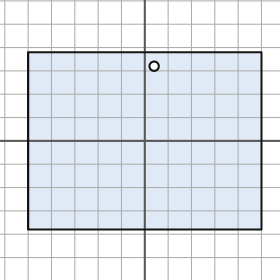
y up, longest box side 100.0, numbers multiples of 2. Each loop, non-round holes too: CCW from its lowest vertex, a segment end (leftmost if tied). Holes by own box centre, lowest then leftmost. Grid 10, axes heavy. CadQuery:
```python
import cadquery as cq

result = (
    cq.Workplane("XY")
    .moveTo(-50.0, -38.0)
    .lineTo(50.0, -38.0)
    .lineTo(50.0, 38.0)
    .lineTo(-50.0, 38.0)
    .close()
    .moveTo(4.0, 32.0)
    .circle(2.0)
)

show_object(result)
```